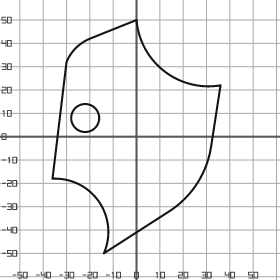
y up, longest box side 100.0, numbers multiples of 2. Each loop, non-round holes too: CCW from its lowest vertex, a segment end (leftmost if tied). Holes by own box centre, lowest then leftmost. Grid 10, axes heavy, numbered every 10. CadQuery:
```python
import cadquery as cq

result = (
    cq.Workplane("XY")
    .moveTo(-14.0, -50.0)
    .lineTo(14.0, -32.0)
    .threePointArc((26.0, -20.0), (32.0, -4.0))
    .lineTo(36.0, 22.0)
    .threePointArc((12.0, 28.0), (0.0, 50.0))
    .lineTo(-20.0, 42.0)
    .threePointArc((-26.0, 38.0), (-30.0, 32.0))
    .lineTo(-36.0, -18.0)
    .threePointArc((-16.0, -28.0), (-14.0, -50.0))
    .close()
    .moveTo(-22.0, 8.0)
    .circle(6.0)
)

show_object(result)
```